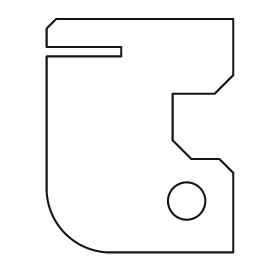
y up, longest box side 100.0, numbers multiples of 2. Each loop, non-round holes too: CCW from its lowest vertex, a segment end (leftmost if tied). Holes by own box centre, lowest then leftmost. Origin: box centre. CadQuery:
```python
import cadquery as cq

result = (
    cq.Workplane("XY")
    .moveTo(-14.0, -50.0)
    .lineTo(40.0, -50.0)
    .lineTo(40.0, -16.0)
    .lineTo(34.0, -10.0)
    .lineTo(22.0, -10.0)
    .lineTo(14.0, -2.0)
    .lineTo(14.0, 18.0)
    .lineTo(32.0, 18.0)
    .lineTo(40.0, 26.0)
    .lineTo(40.0, 50.0)
    .lineTo(-36.0, 50.0)
    .lineTo(-40.0, 46.0)
    .lineTo(-40.0, 38.0)
    .lineTo(-8.0, 38.0)
    .lineTo(-8.0, 34.0)
    .lineTo(-40.0, 34.0)
    .lineTo(-40.0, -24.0)
    .threePointArc((-32.0, -42.0), (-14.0, -50.0))
    .close()
    .moveTo(20.0, -28.0)
    .circle(8.0)
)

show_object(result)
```